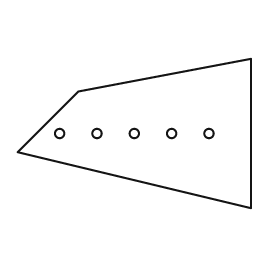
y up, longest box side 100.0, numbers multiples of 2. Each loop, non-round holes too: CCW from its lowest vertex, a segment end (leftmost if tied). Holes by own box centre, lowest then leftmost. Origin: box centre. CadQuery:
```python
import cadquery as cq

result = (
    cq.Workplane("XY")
    .moveTo(50.0, -32.0)
    .lineTo(50.0, 32.0)
    .lineTo(-24.0, 18.0)
    .lineTo(-50.0, -8.0)
    .close()
    .moveTo(-32.0, 0.0)
    .circle(2.0)
    .moveTo(-16.0, 0.0)
    .circle(2.0)
    .moveTo(0.0, 0.0)
    .circle(2.0)
    .moveTo(16.0, 0.0)
    .circle(2.0)
    .moveTo(32.0, 0.0)
    .circle(2.0)
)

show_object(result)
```